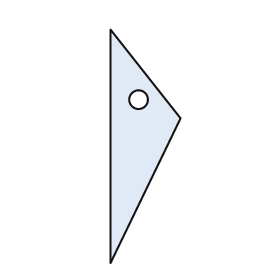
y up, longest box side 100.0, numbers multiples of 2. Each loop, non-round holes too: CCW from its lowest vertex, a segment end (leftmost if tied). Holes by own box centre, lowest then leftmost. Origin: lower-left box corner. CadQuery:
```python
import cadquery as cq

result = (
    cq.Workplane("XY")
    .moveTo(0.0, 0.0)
    .lineTo(30.0, 62.0)
    .lineTo(0.0, 100.0)
    .close()
    .moveTo(12.0, 70.0)
    .circle(4.0)
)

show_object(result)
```